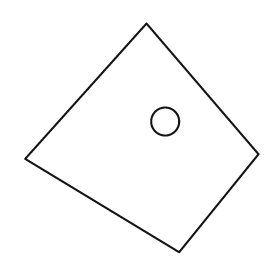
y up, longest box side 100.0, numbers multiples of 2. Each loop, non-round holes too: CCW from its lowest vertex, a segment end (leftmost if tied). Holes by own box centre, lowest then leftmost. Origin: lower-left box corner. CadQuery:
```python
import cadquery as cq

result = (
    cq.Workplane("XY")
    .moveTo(66.0, 0.0)
    .lineTo(100.0, 42.0)
    .lineTo(52.0, 98.0)
    .lineTo(0.0, 40.0)
    .close()
    .moveTo(60.0, 56.0)
    .circle(6.0)
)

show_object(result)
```